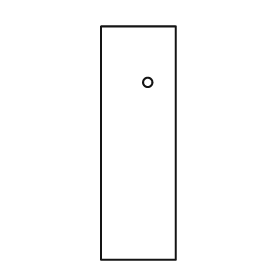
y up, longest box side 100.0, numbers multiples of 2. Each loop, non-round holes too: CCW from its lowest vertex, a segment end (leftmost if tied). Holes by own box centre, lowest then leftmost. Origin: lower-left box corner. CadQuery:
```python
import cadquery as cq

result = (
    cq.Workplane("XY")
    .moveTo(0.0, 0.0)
    .lineTo(32.0, 0.0)
    .lineTo(32.0, 100.0)
    .lineTo(0.0, 100.0)
    .close()
    .moveTo(20.0, 76.0)
    .circle(2.0)
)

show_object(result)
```